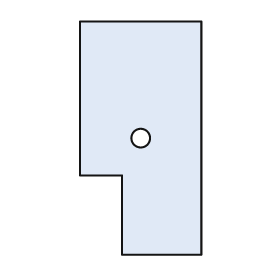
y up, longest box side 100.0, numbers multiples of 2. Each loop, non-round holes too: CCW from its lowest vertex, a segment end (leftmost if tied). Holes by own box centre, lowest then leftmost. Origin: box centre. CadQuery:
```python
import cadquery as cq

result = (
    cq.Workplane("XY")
    .moveTo(-8.0, -50.0)
    .lineTo(26.0, -50.0)
    .lineTo(26.0, 50.0)
    .lineTo(-26.0, 50.0)
    .lineTo(-26.0, -16.0)
    .lineTo(-8.0, -16.0)
    .close()
    .moveTo(0.0, 0.0)
    .circle(4.0)
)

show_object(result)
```